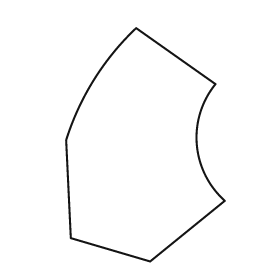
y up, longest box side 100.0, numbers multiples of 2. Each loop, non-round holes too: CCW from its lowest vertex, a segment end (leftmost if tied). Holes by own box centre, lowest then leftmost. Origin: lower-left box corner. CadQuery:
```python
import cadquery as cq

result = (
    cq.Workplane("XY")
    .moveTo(36.0, 0.0)
    .lineTo(68.0, 26.0)
    .threePointArc((56.0, 50.0), (64.0, 76.0))
    .lineTo(30.0, 100.0)
    .threePointArc((12.0, 78.0), (0.0, 52.0))
    .lineTo(2.0, 10.0)
    .close()
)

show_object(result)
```